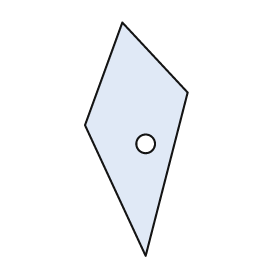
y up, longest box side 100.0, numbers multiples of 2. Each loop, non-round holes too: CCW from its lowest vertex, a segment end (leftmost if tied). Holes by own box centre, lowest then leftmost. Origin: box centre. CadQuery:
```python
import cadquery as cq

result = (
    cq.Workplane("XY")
    .moveTo(4.0, -50.0)
    .lineTo(22.0, 20.0)
    .lineTo(-6.0, 50.0)
    .lineTo(-22.0, 6.0)
    .close()
    .moveTo(4.0, -2.0)
    .circle(4.0)
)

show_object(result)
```